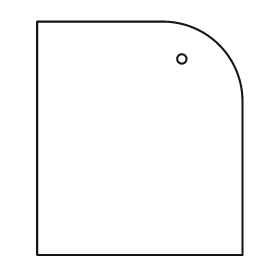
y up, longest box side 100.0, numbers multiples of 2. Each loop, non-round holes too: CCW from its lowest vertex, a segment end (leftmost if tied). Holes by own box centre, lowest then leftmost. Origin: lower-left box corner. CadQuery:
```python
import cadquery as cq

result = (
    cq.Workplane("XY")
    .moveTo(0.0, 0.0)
    .lineTo(88.0, 0.0)
    .lineTo(88.0, 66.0)
    .threePointArc((78.0, 90.0), (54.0, 100.0))
    .lineTo(0.0, 100.0)
    .close()
    .moveTo(62.0, 84.0)
    .circle(2.0)
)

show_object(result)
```